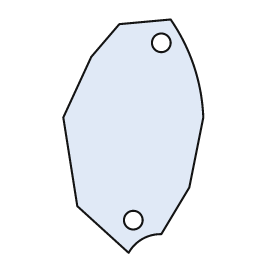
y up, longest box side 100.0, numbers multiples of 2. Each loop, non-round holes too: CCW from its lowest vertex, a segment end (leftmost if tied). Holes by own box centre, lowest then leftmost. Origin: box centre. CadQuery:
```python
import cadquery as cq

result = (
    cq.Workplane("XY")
    .moveTo(-2.0, -50.0)
    .threePointArc((4.0, -44.0), (12.0, -42.0))
    .lineTo(24.0, -22.0)
    .lineTo(30.0, 8.0)
    .threePointArc((26.0, 30.0), (16.0, 50.0))
    .lineTo(-6.0, 48.0)
    .lineTo(-18.0, 34.0)
    .lineTo(-30.0, 8.0)
    .lineTo(-24.0, -30.0)
    .close()
    .moveTo(0.0, -36.0)
    .circle(4.0)
    .moveTo(12.0, 40.0)
    .circle(4.0)
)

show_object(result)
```